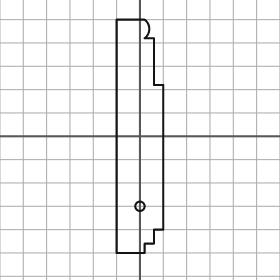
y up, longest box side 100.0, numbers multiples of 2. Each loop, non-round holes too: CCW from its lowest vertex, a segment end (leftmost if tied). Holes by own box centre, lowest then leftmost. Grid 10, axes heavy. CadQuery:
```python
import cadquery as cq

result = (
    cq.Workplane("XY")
    .moveTo(-10.0, -50.0)
    .lineTo(2.0, -50.0)
    .lineTo(2.0, -46.0)
    .lineTo(6.0, -46.0)
    .lineTo(6.0, -40.0)
    .lineTo(10.0, -40.0)
    .lineTo(10.0, 22.0)
    .lineTo(6.0, 22.0)
    .lineTo(6.0, 42.0)
    .lineTo(2.0, 42.0)
    .threePointArc((4.0, 46.0), (2.0, 50.0))
    .lineTo(-10.0, 50.0)
    .close()
    .moveTo(0.0, -30.0)
    .circle(2.0)
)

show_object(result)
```